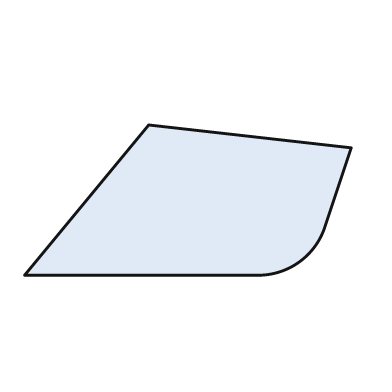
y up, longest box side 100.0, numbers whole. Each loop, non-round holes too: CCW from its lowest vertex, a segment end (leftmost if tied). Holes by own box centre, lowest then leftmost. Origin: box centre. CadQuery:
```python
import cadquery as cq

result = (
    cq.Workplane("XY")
    .moveTo(-50.0, -23.0)
    .lineTo(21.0, -23.0)
    .threePointArc((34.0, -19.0), (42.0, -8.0))
    .lineTo(50.0, 16.0)
    .lineTo(-12.0, 23.0)
    .close()
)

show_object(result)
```